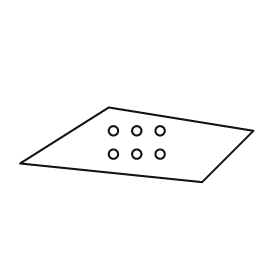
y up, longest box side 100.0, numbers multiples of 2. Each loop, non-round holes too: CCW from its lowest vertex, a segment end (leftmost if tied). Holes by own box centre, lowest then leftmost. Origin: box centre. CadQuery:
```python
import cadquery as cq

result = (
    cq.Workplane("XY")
    .moveTo(28.0, -16.0)
    .lineTo(50.0, 6.0)
    .lineTo(-12.0, 16.0)
    .lineTo(-50.0, -8.0)
    .close()
    .moveTo(-10.0, -4.0)
    .circle(2.0)
    .moveTo(0.0, -4.0)
    .circle(2.0)
    .moveTo(10.0, -4.0)
    .circle(2.0)
    .moveTo(-10.0, 6.0)
    .circle(2.0)
    .moveTo(0.0, 6.0)
    .circle(2.0)
    .moveTo(10.0, 6.0)
    .circle(2.0)
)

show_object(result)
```